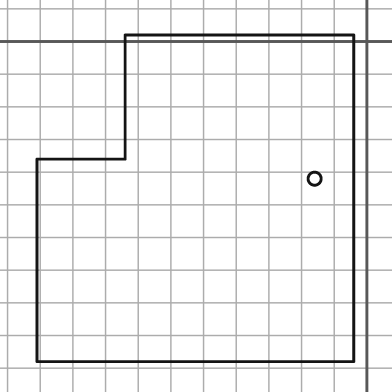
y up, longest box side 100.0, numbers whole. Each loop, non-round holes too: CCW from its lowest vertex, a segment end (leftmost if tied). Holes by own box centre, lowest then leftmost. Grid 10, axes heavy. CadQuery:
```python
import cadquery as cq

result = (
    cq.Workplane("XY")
    .moveTo(-101.0, -98.0)
    .lineTo(-4.0, -98.0)
    .lineTo(-4.0, 2.0)
    .lineTo(-74.0, 2.0)
    .lineTo(-74.0, -36.0)
    .lineTo(-101.0, -36.0)
    .close()
    .moveTo(-16.0, -42.0)
    .circle(2.0)
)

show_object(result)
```